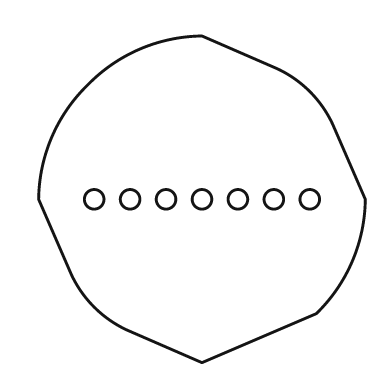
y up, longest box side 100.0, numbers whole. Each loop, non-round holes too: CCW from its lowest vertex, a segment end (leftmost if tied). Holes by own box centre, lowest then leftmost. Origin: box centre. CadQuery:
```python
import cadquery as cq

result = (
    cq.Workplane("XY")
    .moveTo(0.0, -50.0)
    .lineTo(35.0, -35.0)
    .threePointArc((46.0, -19.0), (50.0, 0.0))
    .lineTo(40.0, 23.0)
    .threePointArc((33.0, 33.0), (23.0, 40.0))
    .lineTo(0.0, 50.0)
    .threePointArc((-19.0, 46.0), (-35.0, 35.0))
    .threePointArc((-46.0, 19.0), (-50.0, 0.0))
    .lineTo(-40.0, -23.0)
    .threePointArc((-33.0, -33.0), (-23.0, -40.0))
    .close()
    .moveTo(-33.0, 0.0)
    .circle(3.0)
    .moveTo(-22.0, 0.0)
    .circle(3.0)
    .moveTo(-11.0, 0.0)
    .circle(3.0)
    .moveTo(0.0, 0.0)
    .circle(3.0)
    .moveTo(11.0, 0.0)
    .circle(3.0)
    .moveTo(22.0, 0.0)
    .circle(3.0)
    .moveTo(33.0, 0.0)
    .circle(3.0)
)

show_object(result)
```